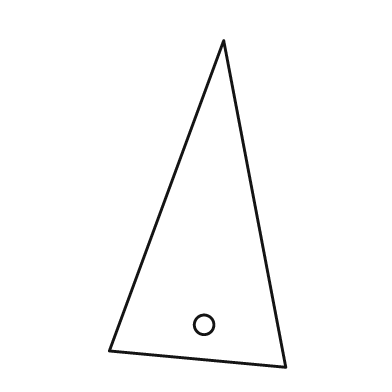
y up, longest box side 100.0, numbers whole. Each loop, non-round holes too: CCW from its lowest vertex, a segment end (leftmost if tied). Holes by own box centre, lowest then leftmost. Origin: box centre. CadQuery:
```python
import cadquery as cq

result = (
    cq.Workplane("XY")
    .moveTo(27.0, -50.0)
    .lineTo(8.0, 50.0)
    .lineTo(-27.0, -45.0)
    .close()
    .moveTo(2.0, -37.0)
    .circle(3.0)
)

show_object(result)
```